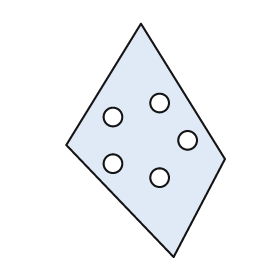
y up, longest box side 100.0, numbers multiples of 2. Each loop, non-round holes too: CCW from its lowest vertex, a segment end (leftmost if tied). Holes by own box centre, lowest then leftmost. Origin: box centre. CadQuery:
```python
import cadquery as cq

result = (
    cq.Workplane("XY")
    .moveTo(12.0, -50.0)
    .lineTo(34.0, -8.0)
    .lineTo(-2.0, 50.0)
    .lineTo(-34.0, -2.0)
    .close()
    .moveTo(6.0, -16.0)
    .circle(4.0)
    .moveTo(-14.0, -10.0)
    .circle(4.0)
    .moveTo(18.0, 0.0)
    .circle(4.0)
    .moveTo(-14.0, 10.0)
    .circle(4.0)
    .moveTo(6.0, 16.0)
    .circle(4.0)
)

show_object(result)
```